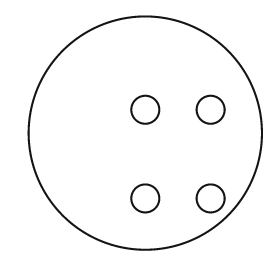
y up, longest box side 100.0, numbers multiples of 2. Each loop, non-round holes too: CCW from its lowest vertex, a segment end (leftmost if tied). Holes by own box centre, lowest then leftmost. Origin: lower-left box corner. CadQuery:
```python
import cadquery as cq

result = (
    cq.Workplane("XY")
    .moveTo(50.0, 50.0)
    .circle(50.0)
    .moveTo(50.0, 22.0)
    .circle(6.0)
    .moveTo(78.0, 22.0)
    .circle(6.0)
    .moveTo(50.0, 60.0)
    .circle(6.0)
    .moveTo(78.0, 60.0)
    .circle(6.0)
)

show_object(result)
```